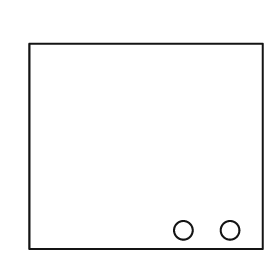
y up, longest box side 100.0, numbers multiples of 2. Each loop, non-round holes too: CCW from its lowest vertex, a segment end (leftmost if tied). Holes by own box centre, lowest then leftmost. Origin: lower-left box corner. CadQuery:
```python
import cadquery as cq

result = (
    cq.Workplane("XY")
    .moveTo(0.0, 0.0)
    .lineTo(100.0, 0.0)
    .lineTo(100.0, 88.0)
    .lineTo(0.0, 88.0)
    .close()
    .moveTo(66.0, 8.0)
    .circle(4.0)
    .moveTo(86.0, 8.0)
    .circle(4.0)
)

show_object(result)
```